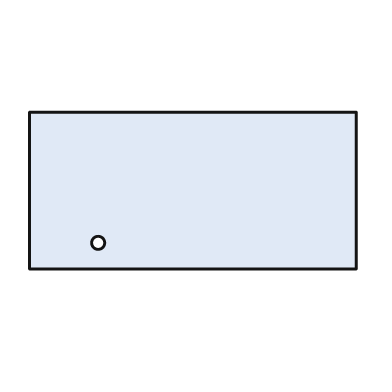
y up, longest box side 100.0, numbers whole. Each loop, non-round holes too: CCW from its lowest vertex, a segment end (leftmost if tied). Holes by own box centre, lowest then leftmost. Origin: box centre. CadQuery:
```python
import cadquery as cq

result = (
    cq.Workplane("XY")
    .moveTo(-50.0, -24.0)
    .lineTo(50.0, -24.0)
    .lineTo(50.0, 24.0)
    .lineTo(-50.0, 24.0)
    .close()
    .moveTo(-29.0, -16.0)
    .circle(2.0)
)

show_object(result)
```